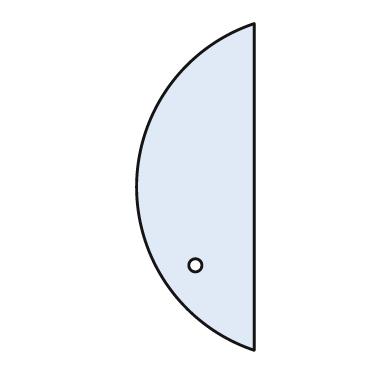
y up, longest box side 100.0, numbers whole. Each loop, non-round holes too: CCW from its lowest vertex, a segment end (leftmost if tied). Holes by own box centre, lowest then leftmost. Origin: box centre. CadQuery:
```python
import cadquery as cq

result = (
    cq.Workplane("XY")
    .moveTo(18.0, -50.0)
    .lineTo(18.0, 50.0)
    .threePointArc((-18.0, 0.0), (18.0, -50.0))
    .close()
    .moveTo(0.0, -24.0)
    .circle(2.0)
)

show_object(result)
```